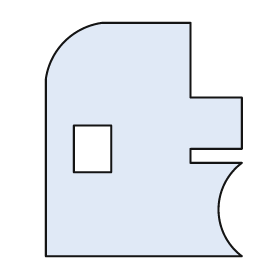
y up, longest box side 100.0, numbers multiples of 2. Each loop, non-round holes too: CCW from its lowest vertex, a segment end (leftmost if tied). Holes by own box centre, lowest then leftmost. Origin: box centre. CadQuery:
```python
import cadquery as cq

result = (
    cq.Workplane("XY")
    .moveTo(-42.0, -50.0)
    .lineTo(42.0, -50.0)
    .threePointArc((32.0, -30.0), (42.0, -10.0))
    .lineTo(20.0, -10.0)
    .lineTo(20.0, -4.0)
    .lineTo(42.0, -4.0)
    .lineTo(42.0, 18.0)
    .lineTo(20.0, 18.0)
    .lineTo(20.0, 50.0)
    .lineTo(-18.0, 50.0)
    .threePointArc((-34.0, 42.0), (-42.0, 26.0))
    .close()
    .moveTo(-30.0, -14.0)
    .lineTo(-14.0, -14.0)
    .lineTo(-14.0, 6.0)
    .lineTo(-30.0, 6.0)
    .close()
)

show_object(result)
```